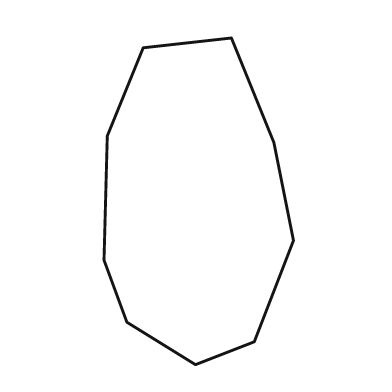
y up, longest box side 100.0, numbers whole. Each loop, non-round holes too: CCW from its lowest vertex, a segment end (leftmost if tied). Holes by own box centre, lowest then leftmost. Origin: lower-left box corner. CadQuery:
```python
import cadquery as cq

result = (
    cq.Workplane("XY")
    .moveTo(28.0, 0.0)
    .lineTo(46.0, 7.0)
    .lineTo(58.0, 38.0)
    .lineTo(52.0, 68.0)
    .lineTo(39.0, 100.0)
    .lineTo(12.0, 97.0)
    .lineTo(1.0, 70.0)
    .lineTo(0.0, 32.0)
    .lineTo(7.0, 13.0)
    .close()
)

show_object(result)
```